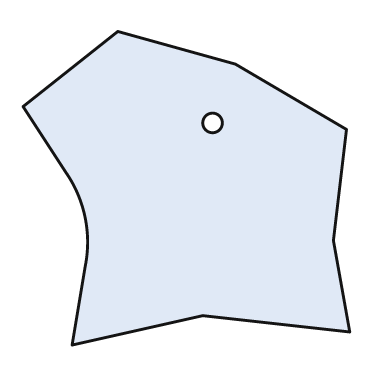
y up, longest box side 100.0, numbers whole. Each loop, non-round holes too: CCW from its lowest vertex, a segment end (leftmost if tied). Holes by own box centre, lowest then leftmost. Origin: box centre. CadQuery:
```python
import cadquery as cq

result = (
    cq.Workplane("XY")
    .moveTo(-35.0, -48.0)
    .lineTo(5.0, -39.0)
    .lineTo(50.0, -44.0)
    .lineTo(45.0, -16.0)
    .lineTo(49.0, 18.0)
    .lineTo(15.0, 38.0)
    .lineTo(-21.0, 48.0)
    .lineTo(-50.0, 25.0)
    .lineTo(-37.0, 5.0)
    .threePointArc((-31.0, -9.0), (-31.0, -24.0))
    .close()
    .moveTo(8.0, 20.0)
    .circle(3.0)
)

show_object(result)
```